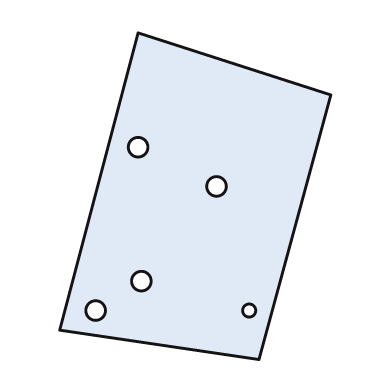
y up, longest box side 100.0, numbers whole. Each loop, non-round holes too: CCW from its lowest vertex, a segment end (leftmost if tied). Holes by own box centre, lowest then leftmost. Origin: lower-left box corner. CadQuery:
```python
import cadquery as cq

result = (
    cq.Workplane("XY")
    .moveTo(61.0, 0.0)
    .lineTo(83.0, 81.0)
    .lineTo(24.0, 100.0)
    .lineTo(0.0, 9.0)
    .close()
    .moveTo(11.0, 15.0)
    .circle(3.0)
    .moveTo(58.0, 15.0)
    .circle(2.0)
    .moveTo(25.0, 24.0)
    .circle(3.0)
    .moveTo(48.0, 53.0)
    .circle(3.0)
    .moveTo(24.0, 65.0)
    .circle(3.0)
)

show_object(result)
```